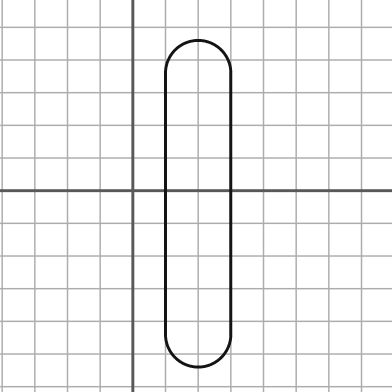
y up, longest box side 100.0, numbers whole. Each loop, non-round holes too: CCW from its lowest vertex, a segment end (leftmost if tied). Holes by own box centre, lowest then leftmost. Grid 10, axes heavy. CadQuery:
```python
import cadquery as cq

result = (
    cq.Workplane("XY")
    .moveTo(10.0, -44.0)
    .threePointArc((20.0, -54.0), (30.0, -44.0))
    .lineTo(30.0, 36.0)
    .threePointArc((20.0, 46.0), (10.0, 36.0))
    .close()
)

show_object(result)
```